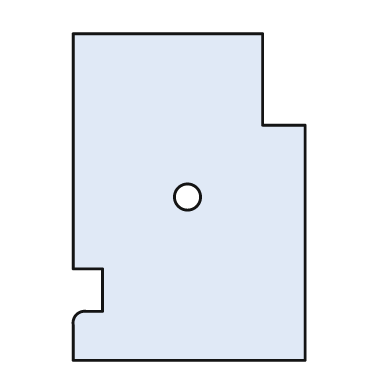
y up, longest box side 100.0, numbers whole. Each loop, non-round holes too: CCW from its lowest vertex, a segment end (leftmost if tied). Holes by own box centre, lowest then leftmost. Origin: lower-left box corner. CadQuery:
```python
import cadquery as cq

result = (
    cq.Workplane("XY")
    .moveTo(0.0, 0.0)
    .lineTo(71.0, 0.0)
    .lineTo(71.0, 72.0)
    .lineTo(58.0, 72.0)
    .lineTo(58.0, 100.0)
    .lineTo(0.0, 100.0)
    .lineTo(0.0, 28.0)
    .lineTo(9.0, 28.0)
    .lineTo(9.0, 15.0)
    .lineTo(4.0, 15.0)
    .threePointArc((1.0, 14.0), (0.0, 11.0))
    .close()
    .moveTo(35.0, 50.0)
    .circle(4.0)
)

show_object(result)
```